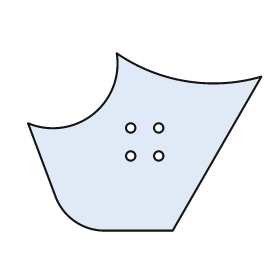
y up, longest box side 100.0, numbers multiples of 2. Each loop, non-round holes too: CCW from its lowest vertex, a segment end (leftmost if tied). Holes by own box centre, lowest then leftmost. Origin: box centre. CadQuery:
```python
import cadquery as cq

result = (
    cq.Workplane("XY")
    .moveTo(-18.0, -38.0)
    .lineTo(12.0, -38.0)
    .lineTo(50.0, 28.0)
    .threePointArc((18.0, 26.0), (-12.0, 38.0))
    .threePointArc((-22.0, 12.0), (-50.0, 8.0))
    .lineTo(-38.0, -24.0)
    .threePointArc((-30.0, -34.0), (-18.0, -38.0))
    .close()
    .moveTo(-6.0, -6.0)
    .circle(2.0)
    .moveTo(6.0, -6.0)
    .circle(2.0)
    .moveTo(-6.0, 6.0)
    .circle(2.0)
    .moveTo(6.0, 6.0)
    .circle(2.0)
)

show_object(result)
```